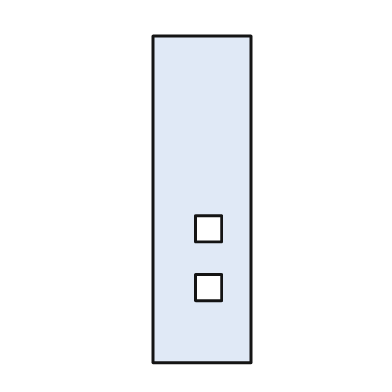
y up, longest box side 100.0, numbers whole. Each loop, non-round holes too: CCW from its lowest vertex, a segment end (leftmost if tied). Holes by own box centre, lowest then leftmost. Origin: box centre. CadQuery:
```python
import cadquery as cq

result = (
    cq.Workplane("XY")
    .moveTo(-15.0, -50.0)
    .lineTo(15.0, -50.0)
    .lineTo(15.0, 50.0)
    .lineTo(-15.0, 50.0)
    .close()
    .moveTo(-2.0, -31.0)
    .lineTo(6.0, -31.0)
    .lineTo(6.0, -23.0)
    .lineTo(-2.0, -23.0)
    .close()
    .moveTo(-2.0, -13.0)
    .lineTo(6.0, -13.0)
    .lineTo(6.0, -5.0)
    .lineTo(-2.0, -5.0)
    .close()
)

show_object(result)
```